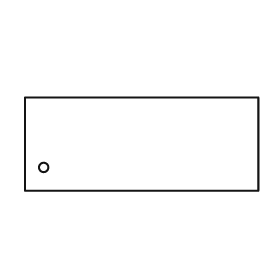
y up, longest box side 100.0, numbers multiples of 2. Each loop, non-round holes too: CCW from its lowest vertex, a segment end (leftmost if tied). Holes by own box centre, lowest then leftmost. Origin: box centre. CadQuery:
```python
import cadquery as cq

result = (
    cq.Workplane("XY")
    .moveTo(-50.0, -20.0)
    .lineTo(50.0, -20.0)
    .lineTo(50.0, 20.0)
    .lineTo(-50.0, 20.0)
    .close()
    .moveTo(-42.0, -10.0)
    .circle(2.0)
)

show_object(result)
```